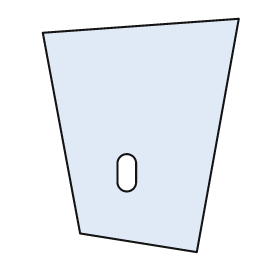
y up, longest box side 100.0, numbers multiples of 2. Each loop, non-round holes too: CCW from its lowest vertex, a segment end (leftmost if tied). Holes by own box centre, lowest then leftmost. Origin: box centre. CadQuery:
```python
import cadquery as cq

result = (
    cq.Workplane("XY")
    .moveTo(24.0, -50.0)
    .lineTo(42.0, 50.0)
    .lineTo(-42.0, 44.0)
    .lineTo(-26.0, -42.0)
    .close()
    .moveTo(-10.0, -20.0)
    .threePointArc((-6.0, -24.0), (-2.0, -20.0))
    .lineTo(-2.0, -12.0)
    .threePointArc((-6.0, -8.0), (-10.0, -12.0))
    .close()
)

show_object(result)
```